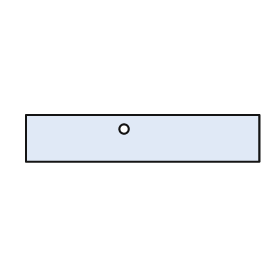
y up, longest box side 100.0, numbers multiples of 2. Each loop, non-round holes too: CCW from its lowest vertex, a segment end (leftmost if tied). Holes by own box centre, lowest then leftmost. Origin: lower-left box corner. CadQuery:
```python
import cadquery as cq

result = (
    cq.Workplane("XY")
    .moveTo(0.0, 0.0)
    .lineTo(100.0, 0.0)
    .lineTo(100.0, 20.0)
    .lineTo(0.0, 20.0)
    .close()
    .moveTo(42.0, 14.0)
    .circle(2.0)
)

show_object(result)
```